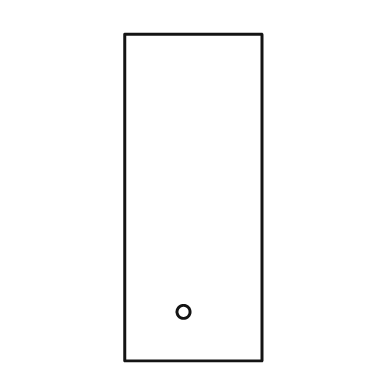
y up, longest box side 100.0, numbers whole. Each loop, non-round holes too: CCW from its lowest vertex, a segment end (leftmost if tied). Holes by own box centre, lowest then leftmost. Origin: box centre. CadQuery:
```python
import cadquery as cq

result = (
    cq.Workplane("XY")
    .moveTo(-21.0, -50.0)
    .lineTo(21.0, -50.0)
    .lineTo(21.0, 50.0)
    .lineTo(-21.0, 50.0)
    .close()
    .moveTo(-3.0, -35.0)
    .circle(2.0)
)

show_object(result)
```